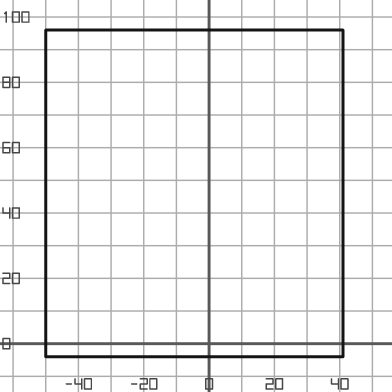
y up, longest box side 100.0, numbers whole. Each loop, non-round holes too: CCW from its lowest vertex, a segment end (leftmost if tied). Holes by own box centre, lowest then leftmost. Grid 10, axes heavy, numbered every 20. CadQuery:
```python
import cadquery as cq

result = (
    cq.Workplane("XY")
    .moveTo(-50.0, -4.0)
    .lineTo(41.0, -4.0)
    .lineTo(41.0, 96.0)
    .lineTo(-50.0, 96.0)
    .close()
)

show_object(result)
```